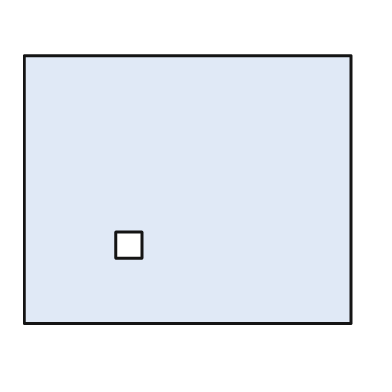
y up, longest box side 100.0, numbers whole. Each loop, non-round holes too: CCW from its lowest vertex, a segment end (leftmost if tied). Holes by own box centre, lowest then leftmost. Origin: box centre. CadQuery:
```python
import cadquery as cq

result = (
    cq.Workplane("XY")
    .moveTo(-50.0, -41.0)
    .lineTo(50.0, -41.0)
    .lineTo(50.0, 41.0)
    .lineTo(-50.0, 41.0)
    .close()
    .moveTo(-22.0, -21.0)
    .lineTo(-14.0, -21.0)
    .lineTo(-14.0, -13.0)
    .lineTo(-22.0, -13.0)
    .close()
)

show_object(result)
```